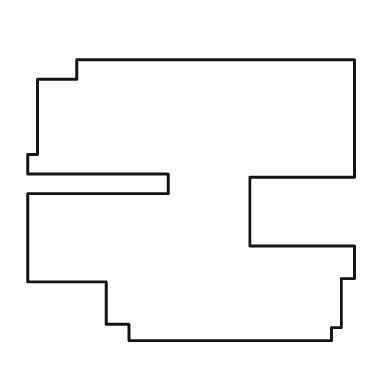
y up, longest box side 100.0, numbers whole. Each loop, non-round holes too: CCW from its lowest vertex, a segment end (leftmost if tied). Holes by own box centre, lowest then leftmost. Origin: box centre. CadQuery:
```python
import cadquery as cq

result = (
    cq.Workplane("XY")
    .moveTo(-19.0, -43.0)
    .lineTo(43.0, -43.0)
    .lineTo(43.0, -39.0)
    .lineTo(46.0, -39.0)
    .lineTo(46.0, -24.0)
    .lineTo(50.0, -24.0)
    .lineTo(50.0, -14.0)
    .lineTo(18.0, -14.0)
    .lineTo(18.0, 7.0)
    .lineTo(50.0, 7.0)
    .lineTo(50.0, 43.0)
    .lineTo(-35.0, 43.0)
    .lineTo(-35.0, 37.0)
    .lineTo(-47.0, 37.0)
    .lineTo(-47.0, 14.0)
    .lineTo(-50.0, 14.0)
    .lineTo(-50.0, 8.0)
    .lineTo(-7.0, 8.0)
    .lineTo(-7.0, 2.0)
    .lineTo(-50.0, 2.0)
    .lineTo(-50.0, -25.0)
    .lineTo(-26.0, -25.0)
    .lineTo(-26.0, -38.0)
    .lineTo(-19.0, -38.0)
    .close()
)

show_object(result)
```